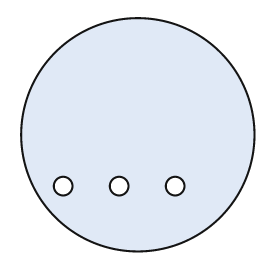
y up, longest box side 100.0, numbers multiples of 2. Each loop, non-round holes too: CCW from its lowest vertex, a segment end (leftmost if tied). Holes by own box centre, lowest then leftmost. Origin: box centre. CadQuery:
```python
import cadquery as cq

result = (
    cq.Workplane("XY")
    .moveTo(0.0, 0.0)
    .circle(50.0)
    .moveTo(-32.0, -22.0)
    .circle(4.0)
    .moveTo(-8.0, -22.0)
    .circle(4.0)
    .moveTo(16.0, -22.0)
    .circle(4.0)
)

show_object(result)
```